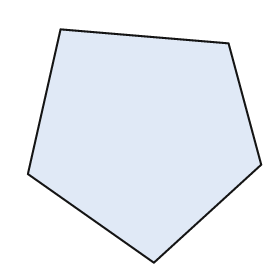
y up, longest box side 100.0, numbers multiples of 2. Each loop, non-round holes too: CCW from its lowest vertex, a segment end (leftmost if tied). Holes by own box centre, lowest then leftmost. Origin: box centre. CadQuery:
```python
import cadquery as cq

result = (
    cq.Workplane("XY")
    .moveTo(4.0, -50.0)
    .lineTo(50.0, -8.0)
    .lineTo(36.0, 44.0)
    .lineTo(-36.0, 50.0)
    .lineTo(-50.0, -12.0)
    .close()
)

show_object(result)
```